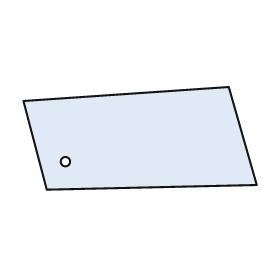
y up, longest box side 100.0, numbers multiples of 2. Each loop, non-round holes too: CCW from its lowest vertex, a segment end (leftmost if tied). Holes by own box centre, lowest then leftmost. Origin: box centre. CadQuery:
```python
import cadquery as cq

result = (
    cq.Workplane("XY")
    .moveTo(-40.0, -22.0)
    .lineTo(50.0, -20.0)
    .lineTo(38.0, 22.0)
    .lineTo(-50.0, 16.0)
    .close()
    .moveTo(-32.0, -10.0)
    .circle(2.0)
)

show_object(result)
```